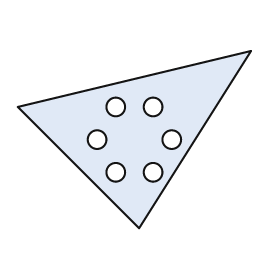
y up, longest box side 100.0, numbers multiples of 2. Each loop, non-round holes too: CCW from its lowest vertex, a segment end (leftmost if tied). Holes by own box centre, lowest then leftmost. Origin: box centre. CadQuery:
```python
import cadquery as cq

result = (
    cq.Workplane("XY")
    .moveTo(2.0, -38.0)
    .lineTo(50.0, 38.0)
    .lineTo(-50.0, 14.0)
    .close()
    .moveTo(-8.0, -14.0)
    .circle(4.0)
    .moveTo(8.0, -14.0)
    .circle(4.0)
    .moveTo(-16.0, 0.0)
    .circle(4.0)
    .moveTo(16.0, 0.0)
    .circle(4.0)
    .moveTo(-8.0, 14.0)
    .circle(4.0)
    .moveTo(8.0, 14.0)
    .circle(4.0)
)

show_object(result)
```